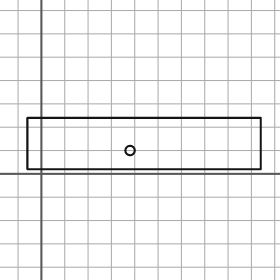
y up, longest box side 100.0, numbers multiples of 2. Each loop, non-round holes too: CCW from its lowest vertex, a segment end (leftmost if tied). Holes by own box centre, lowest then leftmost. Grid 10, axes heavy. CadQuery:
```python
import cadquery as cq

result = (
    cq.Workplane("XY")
    .moveTo(-6.0, 2.0)
    .lineTo(94.0, 2.0)
    .lineTo(94.0, 24.0)
    .lineTo(-6.0, 24.0)
    .close()
    .moveTo(38.0, 10.0)
    .circle(2.0)
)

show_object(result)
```